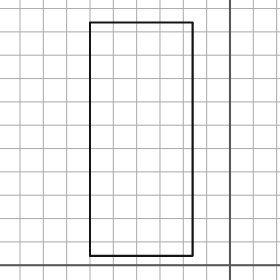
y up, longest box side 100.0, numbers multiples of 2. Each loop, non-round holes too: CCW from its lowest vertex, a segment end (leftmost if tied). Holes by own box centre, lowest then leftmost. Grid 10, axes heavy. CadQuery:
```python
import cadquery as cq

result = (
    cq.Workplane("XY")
    .moveTo(-60.0, 4.0)
    .lineTo(-16.0, 4.0)
    .lineTo(-16.0, 104.0)
    .lineTo(-60.0, 104.0)
    .close()
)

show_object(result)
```